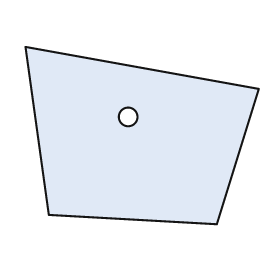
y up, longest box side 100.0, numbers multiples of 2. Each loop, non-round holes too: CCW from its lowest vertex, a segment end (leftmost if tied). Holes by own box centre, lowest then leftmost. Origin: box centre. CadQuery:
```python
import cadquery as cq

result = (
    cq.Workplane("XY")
    .moveTo(32.0, -38.0)
    .lineTo(50.0, 20.0)
    .lineTo(-50.0, 38.0)
    .lineTo(-40.0, -34.0)
    .close()
    .moveTo(-6.0, 8.0)
    .circle(4.0)
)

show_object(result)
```